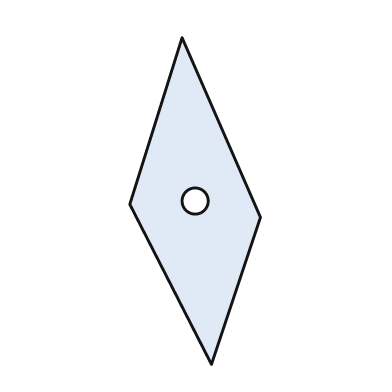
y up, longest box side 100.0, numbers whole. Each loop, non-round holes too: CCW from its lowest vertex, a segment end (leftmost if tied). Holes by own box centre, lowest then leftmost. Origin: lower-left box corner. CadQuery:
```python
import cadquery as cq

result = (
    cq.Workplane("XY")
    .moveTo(25.0, 0.0)
    .lineTo(40.0, 45.0)
    .lineTo(16.0, 100.0)
    .lineTo(0.0, 49.0)
    .close()
    .moveTo(20.0, 50.0)
    .circle(4.0)
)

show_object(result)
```